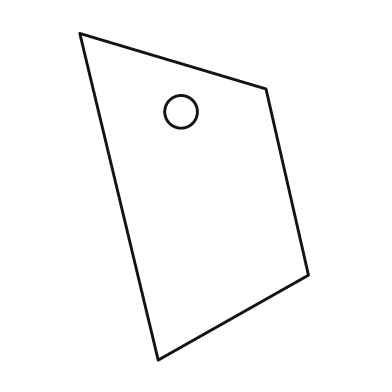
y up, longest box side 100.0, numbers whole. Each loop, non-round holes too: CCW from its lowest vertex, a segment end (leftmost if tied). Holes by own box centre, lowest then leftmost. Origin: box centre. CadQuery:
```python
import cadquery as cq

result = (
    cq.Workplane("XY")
    .moveTo(-11.0, -50.0)
    .lineTo(35.0, -24.0)
    .lineTo(22.0, 33.0)
    .lineTo(-35.0, 50.0)
    .close()
    .moveTo(-4.0, 26.0)
    .circle(5.0)
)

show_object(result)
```